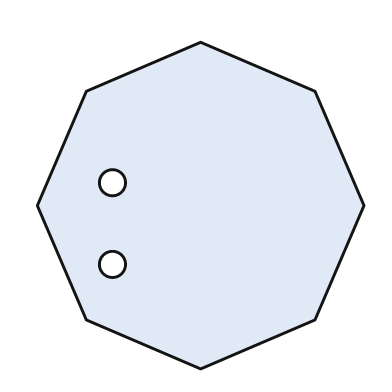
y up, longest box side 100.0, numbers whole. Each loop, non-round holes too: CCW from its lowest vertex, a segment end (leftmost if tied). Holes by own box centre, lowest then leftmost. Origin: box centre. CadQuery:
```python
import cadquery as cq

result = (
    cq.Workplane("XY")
    .moveTo(0.0, -50.0)
    .lineTo(35.0, -35.0)
    .lineTo(50.0, 0.0)
    .lineTo(35.0, 35.0)
    .lineTo(0.0, 50.0)
    .lineTo(-35.0, 35.0)
    .lineTo(-50.0, 0.0)
    .lineTo(-35.0, -35.0)
    .close()
    .moveTo(-27.0, -18.0)
    .circle(4.0)
    .moveTo(-27.0, 7.0)
    .circle(4.0)
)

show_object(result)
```